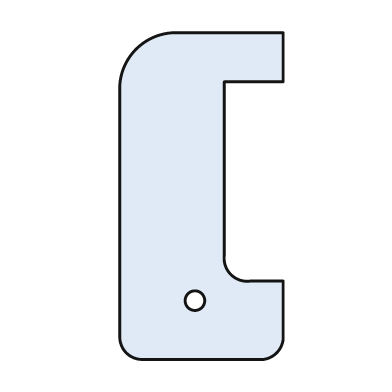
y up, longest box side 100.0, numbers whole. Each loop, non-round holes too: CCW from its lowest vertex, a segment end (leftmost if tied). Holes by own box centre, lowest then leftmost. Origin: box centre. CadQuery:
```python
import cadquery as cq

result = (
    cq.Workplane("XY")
    .moveTo(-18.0, -50.0)
    .lineTo(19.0, -50.0)
    .threePointArc((23.0, -48.0), (25.0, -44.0))
    .lineTo(25.0, -26.0)
    .lineTo(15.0, -26.0)
    .threePointArc((9.0, -24.0), (7.0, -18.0))
    .lineTo(7.0, 35.0)
    .lineTo(25.0, 35.0)
    .lineTo(25.0, 50.0)
    .lineTo(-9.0, 50.0)
    .threePointArc((-20.0, 45.0), (-25.0, 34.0))
    .lineTo(-25.0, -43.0)
    .threePointArc((-23.0, -48.0), (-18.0, -50.0))
    .close()
    .moveTo(-2.0, -32.0)
    .circle(3.0)
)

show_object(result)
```